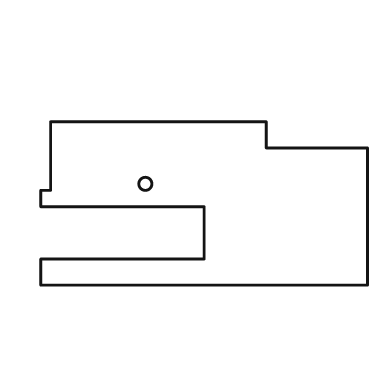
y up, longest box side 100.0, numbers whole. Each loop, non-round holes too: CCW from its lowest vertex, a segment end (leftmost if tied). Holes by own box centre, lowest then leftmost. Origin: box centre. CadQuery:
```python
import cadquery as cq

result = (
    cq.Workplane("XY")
    .moveTo(-50.0, -25.0)
    .lineTo(50.0, -25.0)
    .lineTo(50.0, 17.0)
    .lineTo(19.0, 17.0)
    .lineTo(19.0, 25.0)
    .lineTo(-47.0, 25.0)
    .lineTo(-47.0, 4.0)
    .lineTo(-50.0, 4.0)
    .lineTo(-50.0, -1.0)
    .lineTo(0.0, -1.0)
    .lineTo(0.0, -17.0)
    .lineTo(-50.0, -17.0)
    .close()
    .moveTo(-18.0, 6.0)
    .circle(2.0)
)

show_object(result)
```